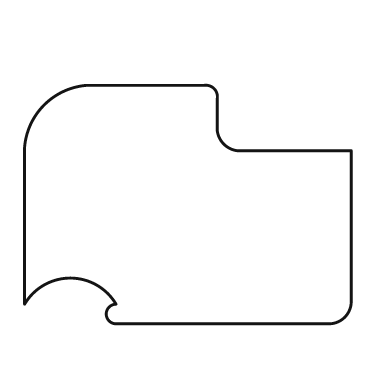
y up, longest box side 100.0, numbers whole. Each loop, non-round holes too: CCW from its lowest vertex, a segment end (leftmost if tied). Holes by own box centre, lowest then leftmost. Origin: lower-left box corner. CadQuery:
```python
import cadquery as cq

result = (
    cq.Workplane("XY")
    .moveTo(28.0, 0.0)
    .lineTo(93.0, 0.0)
    .threePointArc((98.0, 2.0), (100.0, 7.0))
    .lineTo(100.0, 53.0)
    .lineTo(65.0, 53.0)
    .threePointArc((61.0, 55.0), (59.0, 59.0))
    .lineTo(59.0, 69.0)
    .threePointArc((58.0, 72.0), (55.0, 73.0))
    .lineTo(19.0, 73.0)
    .threePointArc((6.0, 67.0), (0.0, 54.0))
    .lineTo(0.0, 6.0)
    .threePointArc((14.0, 14.0), (28.0, 6.0))
    .threePointArc((25.0, 3.0), (28.0, 0.0))
    .close()
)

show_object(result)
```